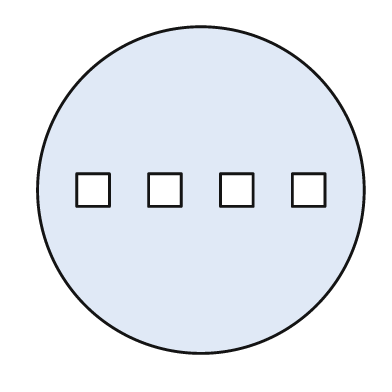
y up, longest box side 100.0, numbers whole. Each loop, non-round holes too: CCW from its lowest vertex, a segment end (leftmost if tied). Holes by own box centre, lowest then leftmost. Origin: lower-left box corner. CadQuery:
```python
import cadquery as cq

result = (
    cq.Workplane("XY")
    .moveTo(50.0, 50.0)
    .circle(50.0)
    .moveTo(12.0, 45.0)
    .lineTo(22.0, 45.0)
    .lineTo(22.0, 55.0)
    .lineTo(12.0, 55.0)
    .close()
    .moveTo(34.0, 45.0)
    .lineTo(44.0, 45.0)
    .lineTo(44.0, 55.0)
    .lineTo(34.0, 55.0)
    .close()
    .moveTo(56.0, 45.0)
    .lineTo(66.0, 45.0)
    .lineTo(66.0, 55.0)
    .lineTo(56.0, 55.0)
    .close()
    .moveTo(78.0, 45.0)
    .lineTo(88.0, 45.0)
    .lineTo(88.0, 55.0)
    .lineTo(78.0, 55.0)
    .close()
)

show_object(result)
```